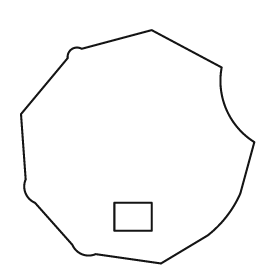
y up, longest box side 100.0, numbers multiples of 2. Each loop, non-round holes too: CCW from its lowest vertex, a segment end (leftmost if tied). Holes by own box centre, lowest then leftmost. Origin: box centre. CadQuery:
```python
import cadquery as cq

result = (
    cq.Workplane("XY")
    .moveTo(10.0, -50.0)
    .lineTo(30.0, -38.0)
    .threePointArc((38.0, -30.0), (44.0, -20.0))
    .lineTo(50.0, 2.0)
    .threePointArc((38.0, 16.0), (36.0, 34.0))
    .lineTo(6.0, 50.0)
    .lineTo(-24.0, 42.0)
    .threePointArc((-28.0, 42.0), (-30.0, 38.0))
    .lineTo(-50.0, 14.0)
    .lineTo(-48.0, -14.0)
    .threePointArc((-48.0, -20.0), (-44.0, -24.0))
    .lineTo(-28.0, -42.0)
    .threePointArc((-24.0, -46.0), (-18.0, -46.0))
    .close()
    .moveTo(-10.0, -36.0)
    .lineTo(6.0, -36.0)
    .lineTo(6.0, -24.0)
    .lineTo(-10.0, -24.0)
    .close()
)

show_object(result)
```